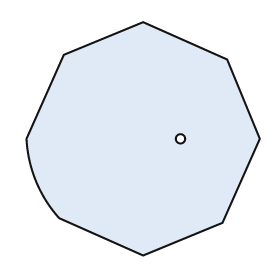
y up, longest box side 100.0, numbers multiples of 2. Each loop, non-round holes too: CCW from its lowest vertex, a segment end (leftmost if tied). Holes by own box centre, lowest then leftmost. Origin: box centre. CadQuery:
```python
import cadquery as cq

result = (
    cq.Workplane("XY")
    .moveTo(0.0, -50.0)
    .lineTo(34.0, -36.0)
    .lineTo(50.0, 0.0)
    .lineTo(36.0, 34.0)
    .lineTo(0.0, 50.0)
    .lineTo(-34.0, 36.0)
    .lineTo(-50.0, 0.0)
    .threePointArc((-46.0, -18.0), (-36.0, -34.0))
    .close()
    .moveTo(16.0, 0.0)
    .circle(2.0)
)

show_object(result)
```